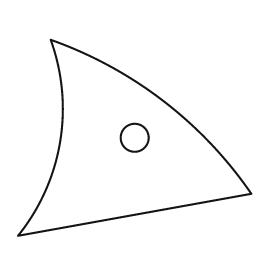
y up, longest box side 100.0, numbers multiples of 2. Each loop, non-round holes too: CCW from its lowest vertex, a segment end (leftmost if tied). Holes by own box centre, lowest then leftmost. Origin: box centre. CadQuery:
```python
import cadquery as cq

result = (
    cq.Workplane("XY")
    .moveTo(-50.0, -42.0)
    .lineTo(50.0, -24.0)
    .threePointArc((12.0, 16.0), (-36.0, 42.0))
    .threePointArc((-32.0, -2.0), (-50.0, -42.0))
    .close()
    .moveTo(0.0, 0.0)
    .circle(6.0)
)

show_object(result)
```